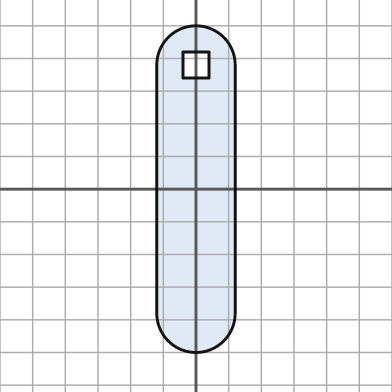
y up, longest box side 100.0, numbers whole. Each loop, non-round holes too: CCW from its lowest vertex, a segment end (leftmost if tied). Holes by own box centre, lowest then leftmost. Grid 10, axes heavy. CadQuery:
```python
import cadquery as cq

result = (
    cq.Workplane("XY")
    .moveTo(-12.0, -38.0)
    .threePointArc((0.0, -50.0), (12.0, -38.0))
    .lineTo(12.0, 38.0)
    .threePointArc((0.0, 50.0), (-12.0, 38.0))
    .close()
    .moveTo(-4.0, 34.0)
    .lineTo(4.0, 34.0)
    .lineTo(4.0, 42.0)
    .lineTo(-4.0, 42.0)
    .close()
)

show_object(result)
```